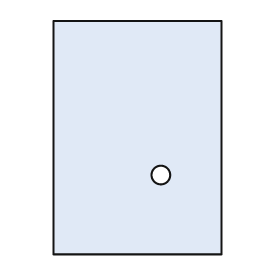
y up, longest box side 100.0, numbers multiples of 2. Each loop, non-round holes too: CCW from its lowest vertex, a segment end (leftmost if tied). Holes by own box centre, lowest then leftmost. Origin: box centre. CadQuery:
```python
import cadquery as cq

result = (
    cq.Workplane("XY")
    .moveTo(-36.0, -50.0)
    .lineTo(36.0, -50.0)
    .lineTo(36.0, 50.0)
    .lineTo(-36.0, 50.0)
    .close()
    .moveTo(10.0, -16.0)
    .circle(4.0)
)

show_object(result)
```